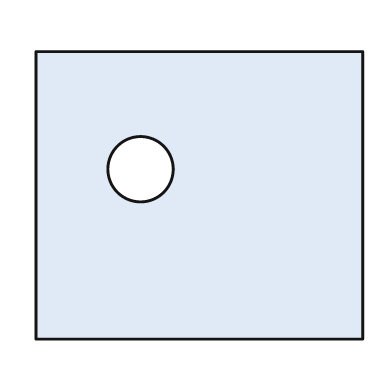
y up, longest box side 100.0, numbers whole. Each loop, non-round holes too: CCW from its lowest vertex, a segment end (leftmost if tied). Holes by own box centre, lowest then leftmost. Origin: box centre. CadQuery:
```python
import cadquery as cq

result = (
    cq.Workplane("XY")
    .moveTo(-50.0, -44.0)
    .lineTo(50.0, -44.0)
    .lineTo(50.0, 44.0)
    .lineTo(-50.0, 44.0)
    .close()
    .moveTo(-18.0, 8.0)
    .circle(10.0)
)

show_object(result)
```